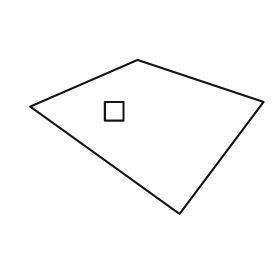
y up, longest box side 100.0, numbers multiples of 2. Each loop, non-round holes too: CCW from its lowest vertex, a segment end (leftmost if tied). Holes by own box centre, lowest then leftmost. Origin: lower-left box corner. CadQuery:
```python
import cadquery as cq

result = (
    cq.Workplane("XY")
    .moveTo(64.0, 0.0)
    .lineTo(100.0, 48.0)
    .lineTo(46.0, 66.0)
    .lineTo(0.0, 46.0)
    .close()
    .moveTo(32.0, 40.0)
    .lineTo(40.0, 40.0)
    .lineTo(40.0, 48.0)
    .lineTo(32.0, 48.0)
    .close()
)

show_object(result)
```